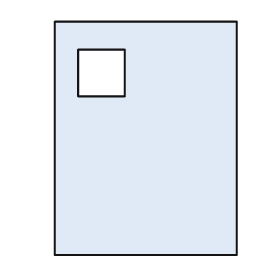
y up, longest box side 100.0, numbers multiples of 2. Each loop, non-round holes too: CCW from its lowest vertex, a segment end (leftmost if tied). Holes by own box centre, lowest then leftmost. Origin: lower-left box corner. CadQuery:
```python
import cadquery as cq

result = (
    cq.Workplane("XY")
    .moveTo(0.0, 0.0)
    .lineTo(78.0, 0.0)
    .lineTo(78.0, 100.0)
    .lineTo(0.0, 100.0)
    .close()
    .moveTo(10.0, 68.0)
    .lineTo(30.0, 68.0)
    .lineTo(30.0, 88.0)
    .lineTo(10.0, 88.0)
    .close()
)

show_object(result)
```